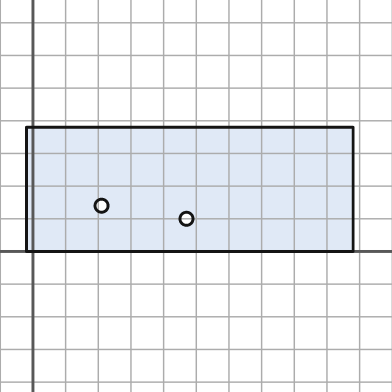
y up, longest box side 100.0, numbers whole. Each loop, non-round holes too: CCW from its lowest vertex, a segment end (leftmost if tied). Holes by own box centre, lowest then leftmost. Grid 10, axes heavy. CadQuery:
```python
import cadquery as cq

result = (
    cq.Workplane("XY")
    .moveTo(-2.0, 0.0)
    .lineTo(98.0, 0.0)
    .lineTo(98.0, 38.0)
    .lineTo(-2.0, 38.0)
    .close()
    .moveTo(47.0, 10.0)
    .circle(2.0)
    .moveTo(21.0, 14.0)
    .circle(2.0)
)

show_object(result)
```